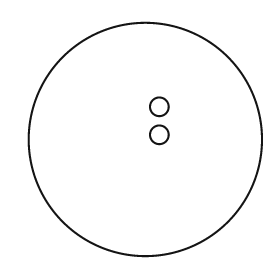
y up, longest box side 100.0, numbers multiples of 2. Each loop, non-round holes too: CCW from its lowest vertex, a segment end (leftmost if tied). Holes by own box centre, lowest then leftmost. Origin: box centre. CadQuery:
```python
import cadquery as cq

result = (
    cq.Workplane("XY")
    .moveTo(0.0, 0.0)
    .circle(50.0)
    .moveTo(6.0, 2.0)
    .circle(4.0)
    .moveTo(6.0, 14.0)
    .circle(4.0)
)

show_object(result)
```